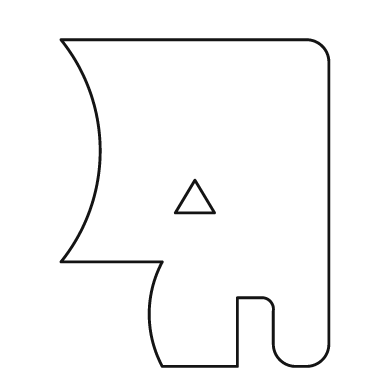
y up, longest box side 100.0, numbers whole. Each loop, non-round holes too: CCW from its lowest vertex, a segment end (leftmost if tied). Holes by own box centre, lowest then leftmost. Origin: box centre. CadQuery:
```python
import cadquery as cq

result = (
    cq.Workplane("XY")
    .moveTo(-10.0, -50.0)
    .lineTo(13.0, -50.0)
    .lineTo(13.0, -29.0)
    .lineTo(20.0, -29.0)
    .threePointArc((23.0, -30.0), (24.0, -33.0))
    .lineTo(24.0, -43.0)
    .threePointArc((26.0, -48.0), (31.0, -50.0))
    .lineTo(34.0, -50.0)
    .threePointArc((39.0, -48.0), (41.0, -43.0))
    .lineTo(41.0, 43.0)
    .threePointArc((39.0, 48.0), (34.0, 50.0))
    .lineTo(-41.0, 50.0)
    .threePointArc((-29.0, 16.0), (-41.0, -18.0))
    .lineTo(-10.0, -18.0)
    .threePointArc((-14.0, -34.0), (-10.0, -50.0))
    .close()
    .moveTo(-6.0, -3.0)
    .lineTo(6.0, -3.0)
    .lineTo(0.0, 7.0)
    .close()
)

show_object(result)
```